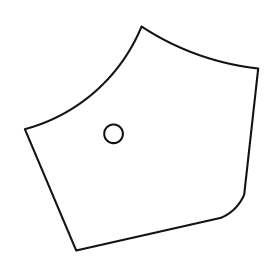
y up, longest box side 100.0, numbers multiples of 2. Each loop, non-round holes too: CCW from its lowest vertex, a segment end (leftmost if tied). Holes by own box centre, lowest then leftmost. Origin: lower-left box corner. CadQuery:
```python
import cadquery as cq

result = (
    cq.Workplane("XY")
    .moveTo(22.0, 0.0)
    .lineTo(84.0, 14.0)
    .threePointArc((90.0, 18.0), (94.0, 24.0))
    .lineTo(100.0, 78.0)
    .threePointArc((74.0, 84.0), (50.0, 96.0))
    .threePointArc((30.0, 68.0), (0.0, 52.0))
    .close()
    .moveTo(38.0, 50.0)
    .circle(4.0)
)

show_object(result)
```